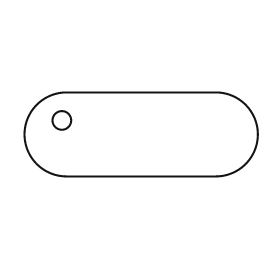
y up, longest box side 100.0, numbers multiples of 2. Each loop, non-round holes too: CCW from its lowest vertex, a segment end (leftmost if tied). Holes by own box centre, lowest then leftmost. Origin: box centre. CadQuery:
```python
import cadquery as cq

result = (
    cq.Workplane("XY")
    .moveTo(-32.0, -18.0)
    .lineTo(32.0, -18.0)
    .threePointArc((50.0, 0.0), (32.0, 18.0))
    .lineTo(-32.0, 18.0)
    .threePointArc((-50.0, 0.0), (-32.0, -18.0))
    .close()
    .moveTo(-34.0, 6.0)
    .circle(4.0)
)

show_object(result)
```